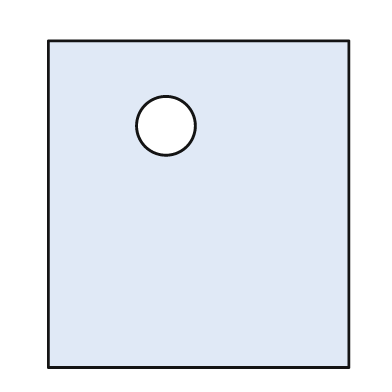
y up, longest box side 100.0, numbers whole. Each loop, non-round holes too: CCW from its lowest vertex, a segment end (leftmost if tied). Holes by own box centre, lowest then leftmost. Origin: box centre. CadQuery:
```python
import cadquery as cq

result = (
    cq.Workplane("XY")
    .moveTo(-46.0, -50.0)
    .lineTo(46.0, -50.0)
    .lineTo(46.0, 50.0)
    .lineTo(-46.0, 50.0)
    .close()
    .moveTo(-10.0, 24.0)
    .circle(9.0)
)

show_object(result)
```